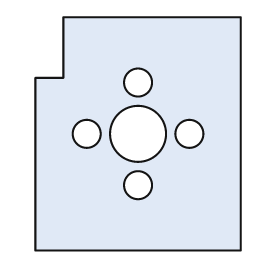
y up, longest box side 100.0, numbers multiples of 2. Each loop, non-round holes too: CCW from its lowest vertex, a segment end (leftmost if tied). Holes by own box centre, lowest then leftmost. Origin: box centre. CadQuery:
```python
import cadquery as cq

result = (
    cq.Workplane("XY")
    .moveTo(-44.0, -50.0)
    .lineTo(44.0, -50.0)
    .lineTo(44.0, 50.0)
    .lineTo(-32.0, 50.0)
    .lineTo(-32.0, 24.0)
    .lineTo(-44.0, 24.0)
    .close()
    .moveTo(0.0, -22.0)
    .circle(6.0)
    .moveTo(-22.0, 0.0)
    .circle(6.0)
    .moveTo(0.0, 0.0)
    .circle(12.0)
    .moveTo(22.0, 0.0)
    .circle(6.0)
    .moveTo(0.0, 22.0)
    .circle(6.0)
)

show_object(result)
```